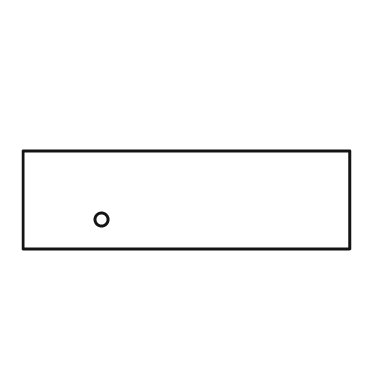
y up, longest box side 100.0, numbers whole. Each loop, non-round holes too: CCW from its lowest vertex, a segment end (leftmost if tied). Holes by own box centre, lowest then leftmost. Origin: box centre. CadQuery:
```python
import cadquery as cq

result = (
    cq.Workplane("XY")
    .moveTo(-50.0, -15.0)
    .lineTo(50.0, -15.0)
    .lineTo(50.0, 15.0)
    .lineTo(-50.0, 15.0)
    .close()
    .moveTo(-26.0, -6.0)
    .circle(2.0)
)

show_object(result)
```